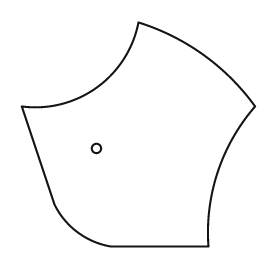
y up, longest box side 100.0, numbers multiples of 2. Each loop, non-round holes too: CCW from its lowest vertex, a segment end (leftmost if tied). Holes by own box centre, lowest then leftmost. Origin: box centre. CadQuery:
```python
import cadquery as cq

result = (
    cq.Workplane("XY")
    .moveTo(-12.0, -48.0)
    .lineTo(30.0, -48.0)
    .threePointArc((34.0, -16.0), (50.0, 12.0))
    .threePointArc((28.0, 34.0), (0.0, 48.0))
    .threePointArc((-18.0, 20.0), (-50.0, 12.0))
    .lineTo(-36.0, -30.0)
    .threePointArc((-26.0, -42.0), (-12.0, -48.0))
    .close()
    .moveTo(-18.0, -6.0)
    .circle(2.0)
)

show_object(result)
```